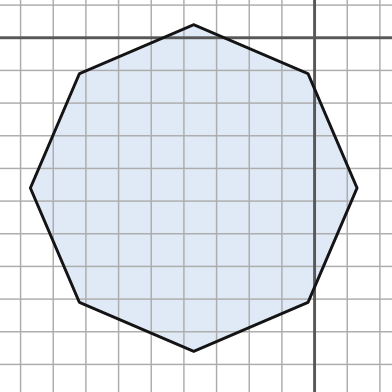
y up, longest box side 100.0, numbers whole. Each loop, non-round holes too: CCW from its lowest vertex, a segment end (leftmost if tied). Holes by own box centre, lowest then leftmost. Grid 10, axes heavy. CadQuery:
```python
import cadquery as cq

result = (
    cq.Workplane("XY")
    .moveTo(-37.0, -96.0)
    .lineTo(-2.0, -81.0)
    .lineTo(13.0, -46.0)
    .lineTo(-2.0, -11.0)
    .lineTo(-37.0, 4.0)
    .lineTo(-72.0, -11.0)
    .lineTo(-87.0, -46.0)
    .lineTo(-72.0, -81.0)
    .close()
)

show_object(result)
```